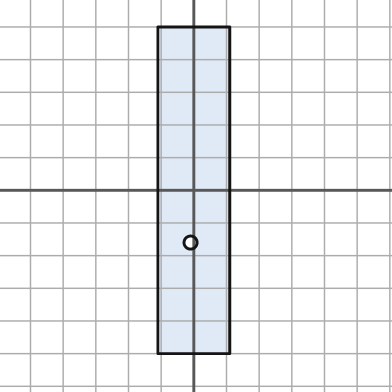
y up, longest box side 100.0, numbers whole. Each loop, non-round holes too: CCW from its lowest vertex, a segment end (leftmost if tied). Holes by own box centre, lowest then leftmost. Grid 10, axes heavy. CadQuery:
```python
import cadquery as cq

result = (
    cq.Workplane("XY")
    .moveTo(-11.0, -50.0)
    .lineTo(11.0, -50.0)
    .lineTo(11.0, 50.0)
    .lineTo(-11.0, 50.0)
    .close()
    .moveTo(-1.0, -16.0)
    .circle(2.0)
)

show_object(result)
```